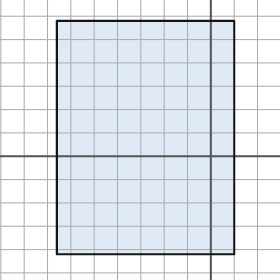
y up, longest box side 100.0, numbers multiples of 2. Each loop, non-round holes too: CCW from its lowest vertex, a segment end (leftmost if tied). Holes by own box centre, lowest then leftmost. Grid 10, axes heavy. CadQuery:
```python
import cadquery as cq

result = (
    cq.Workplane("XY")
    .moveTo(-66.0, -42.0)
    .lineTo(10.0, -42.0)
    .lineTo(10.0, 58.0)
    .lineTo(-66.0, 58.0)
    .close()
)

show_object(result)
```